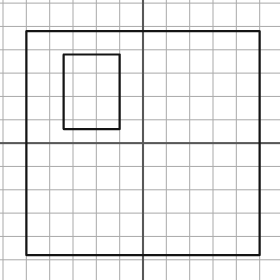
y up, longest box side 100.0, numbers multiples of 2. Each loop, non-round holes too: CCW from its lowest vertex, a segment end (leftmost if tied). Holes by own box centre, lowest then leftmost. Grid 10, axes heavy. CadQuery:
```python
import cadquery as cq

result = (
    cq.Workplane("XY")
    .moveTo(-50.0, -48.0)
    .lineTo(50.0, -48.0)
    .lineTo(50.0, 48.0)
    .lineTo(-50.0, 48.0)
    .close()
    .moveTo(-34.0, 6.0)
    .lineTo(-10.0, 6.0)
    .lineTo(-10.0, 38.0)
    .lineTo(-34.0, 38.0)
    .close()
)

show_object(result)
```